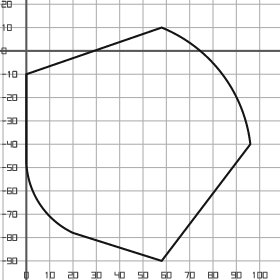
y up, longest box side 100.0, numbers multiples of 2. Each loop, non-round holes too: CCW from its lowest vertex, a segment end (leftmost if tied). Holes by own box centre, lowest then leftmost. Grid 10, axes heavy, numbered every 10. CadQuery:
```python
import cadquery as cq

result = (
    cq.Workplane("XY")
    .moveTo(58.0, -90.0)
    .lineTo(96.0, -40.0)
    .threePointArc((84.0, -10.0), (58.0, 10.0))
    .lineTo(0.0, -10.0)
    .lineTo(0.0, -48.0)
    .threePointArc((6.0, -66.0), (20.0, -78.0))
    .close()
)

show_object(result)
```